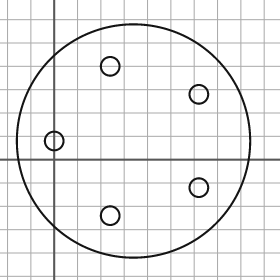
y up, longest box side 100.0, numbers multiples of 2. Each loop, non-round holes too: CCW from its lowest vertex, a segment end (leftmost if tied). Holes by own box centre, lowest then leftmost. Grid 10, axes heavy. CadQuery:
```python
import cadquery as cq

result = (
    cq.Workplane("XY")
    .moveTo(34.0, 8.0)
    .circle(50.0)
    .moveTo(24.0, -24.0)
    .circle(4.0)
    .moveTo(62.0, -12.0)
    .circle(4.0)
    .moveTo(0.0, 8.0)
    .circle(4.0)
    .moveTo(62.0, 28.0)
    .circle(4.0)
    .moveTo(24.0, 40.0)
    .circle(4.0)
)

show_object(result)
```